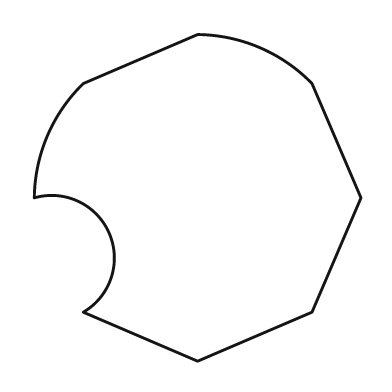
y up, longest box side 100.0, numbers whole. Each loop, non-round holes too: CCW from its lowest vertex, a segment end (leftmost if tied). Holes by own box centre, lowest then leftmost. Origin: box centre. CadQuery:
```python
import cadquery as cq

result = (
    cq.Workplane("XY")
    .moveTo(0.0, -50.0)
    .lineTo(35.0, -35.0)
    .lineTo(50.0, 0.0)
    .lineTo(35.0, 35.0)
    .threePointArc((19.0, 46.0), (0.0, 50.0))
    .lineTo(-35.0, 35.0)
    .threePointArc((-46.0, 19.0), (-50.0, 0.0))
    .threePointArc((-27.0, -11.0), (-35.0, -35.0))
    .close()
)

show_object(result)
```